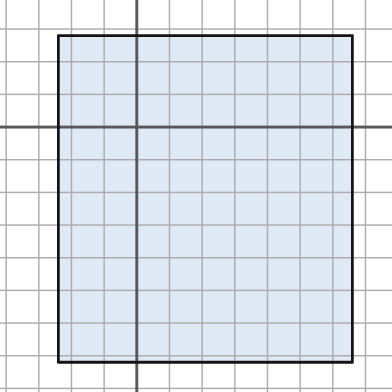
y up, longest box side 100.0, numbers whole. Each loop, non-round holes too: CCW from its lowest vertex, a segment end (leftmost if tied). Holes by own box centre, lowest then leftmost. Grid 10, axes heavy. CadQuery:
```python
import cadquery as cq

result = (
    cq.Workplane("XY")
    .moveTo(-24.0, -72.0)
    .lineTo(66.0, -72.0)
    .lineTo(66.0, 28.0)
    .lineTo(-24.0, 28.0)
    .close()
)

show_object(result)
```